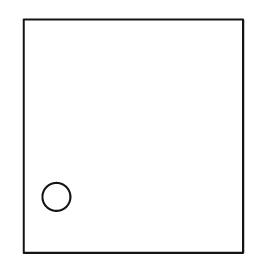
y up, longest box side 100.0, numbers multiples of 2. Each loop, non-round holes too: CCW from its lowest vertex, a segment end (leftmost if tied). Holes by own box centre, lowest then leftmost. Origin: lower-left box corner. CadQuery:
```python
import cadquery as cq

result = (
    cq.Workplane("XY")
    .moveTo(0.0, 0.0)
    .lineTo(94.0, 0.0)
    .lineTo(94.0, 100.0)
    .lineTo(0.0, 100.0)
    .close()
    .moveTo(14.0, 24.0)
    .circle(6.0)
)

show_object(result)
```